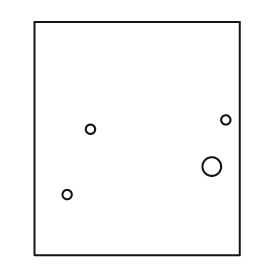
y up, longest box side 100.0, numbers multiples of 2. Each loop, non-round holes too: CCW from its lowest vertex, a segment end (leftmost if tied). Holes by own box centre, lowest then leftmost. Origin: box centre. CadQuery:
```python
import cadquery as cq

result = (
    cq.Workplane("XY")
    .moveTo(-44.0, -50.0)
    .lineTo(44.0, -50.0)
    .lineTo(44.0, 50.0)
    .lineTo(-44.0, 50.0)
    .close()
    .moveTo(-30.0, -24.0)
    .circle(2.0)
    .moveTo(32.0, -12.0)
    .circle(4.0)
    .moveTo(-20.0, 4.0)
    .circle(2.0)
    .moveTo(38.0, 8.0)
    .circle(2.0)
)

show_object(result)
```